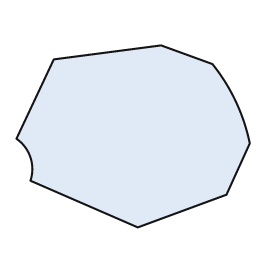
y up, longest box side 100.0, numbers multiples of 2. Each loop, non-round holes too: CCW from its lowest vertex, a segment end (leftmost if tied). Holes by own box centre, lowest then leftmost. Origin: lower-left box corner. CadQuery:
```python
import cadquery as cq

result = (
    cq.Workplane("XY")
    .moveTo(52.0, 0.0)
    .lineTo(90.0, 14.0)
    .lineTo(100.0, 36.0)
    .threePointArc((94.0, 54.0), (84.0, 70.0))
    .lineTo(62.0, 78.0)
    .lineTo(16.0, 72.0)
    .lineTo(0.0, 38.0)
    .threePointArc((6.0, 30.0), (6.0, 20.0))
    .close()
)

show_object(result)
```